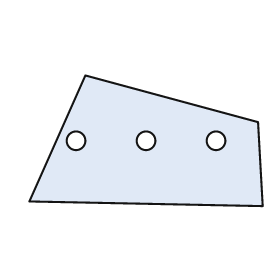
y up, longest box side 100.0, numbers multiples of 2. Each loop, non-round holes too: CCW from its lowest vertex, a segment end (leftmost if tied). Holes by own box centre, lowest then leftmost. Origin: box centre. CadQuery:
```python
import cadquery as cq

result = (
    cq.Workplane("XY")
    .moveTo(50.0, -28.0)
    .lineTo(48.0, 8.0)
    .lineTo(-26.0, 28.0)
    .lineTo(-50.0, -26.0)
    .close()
    .moveTo(-30.0, 0.0)
    .circle(4.0)
    .moveTo(0.0, 0.0)
    .circle(4.0)
    .moveTo(30.0, 0.0)
    .circle(4.0)
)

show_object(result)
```